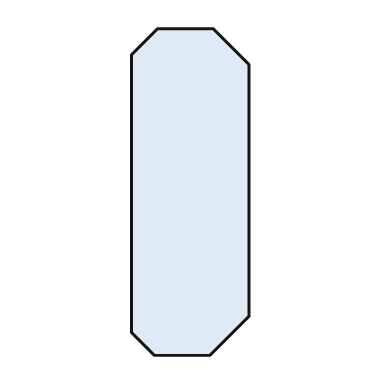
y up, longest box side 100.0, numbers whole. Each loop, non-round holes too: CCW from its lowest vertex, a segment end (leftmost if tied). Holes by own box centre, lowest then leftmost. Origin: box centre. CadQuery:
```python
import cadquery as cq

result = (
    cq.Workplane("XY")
    .moveTo(-11.0, -50.0)
    .lineTo(6.0, -50.0)
    .lineTo(18.0, -38.0)
    .lineTo(18.0, 39.0)
    .lineTo(7.0, 50.0)
    .lineTo(-10.0, 50.0)
    .lineTo(-18.0, 42.0)
    .lineTo(-18.0, -43.0)
    .close()
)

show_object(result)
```